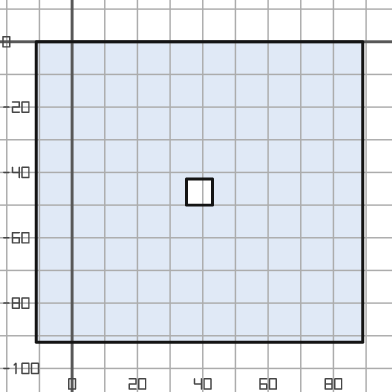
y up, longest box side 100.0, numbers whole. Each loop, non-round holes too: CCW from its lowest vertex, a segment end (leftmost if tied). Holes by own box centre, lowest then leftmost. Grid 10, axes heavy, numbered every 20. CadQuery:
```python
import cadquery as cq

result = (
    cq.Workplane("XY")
    .moveTo(-11.0, -92.0)
    .lineTo(89.0, -92.0)
    .lineTo(89.0, 0.0)
    .lineTo(-11.0, 0.0)
    .close()
    .moveTo(35.0, -50.0)
    .lineTo(43.0, -50.0)
    .lineTo(43.0, -42.0)
    .lineTo(35.0, -42.0)
    .close()
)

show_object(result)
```